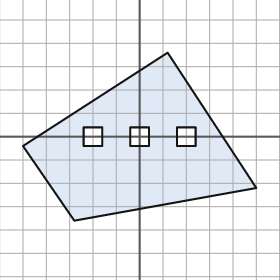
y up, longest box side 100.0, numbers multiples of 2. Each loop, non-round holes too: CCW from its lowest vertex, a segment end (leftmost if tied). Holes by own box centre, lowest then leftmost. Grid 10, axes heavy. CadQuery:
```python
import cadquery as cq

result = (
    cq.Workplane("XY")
    .moveTo(-28.0, -36.0)
    .lineTo(50.0, -22.0)
    .lineTo(12.0, 36.0)
    .lineTo(-50.0, -4.0)
    .close()
    .moveTo(-24.0, -4.0)
    .lineTo(-16.0, -4.0)
    .lineTo(-16.0, 4.0)
    .lineTo(-24.0, 4.0)
    .close()
    .moveTo(-4.0, -4.0)
    .lineTo(4.0, -4.0)
    .lineTo(4.0, 4.0)
    .lineTo(-4.0, 4.0)
    .close()
    .moveTo(16.0, -4.0)
    .lineTo(24.0, -4.0)
    .lineTo(24.0, 4.0)
    .lineTo(16.0, 4.0)
    .close()
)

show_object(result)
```